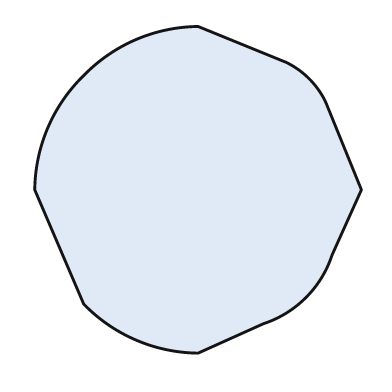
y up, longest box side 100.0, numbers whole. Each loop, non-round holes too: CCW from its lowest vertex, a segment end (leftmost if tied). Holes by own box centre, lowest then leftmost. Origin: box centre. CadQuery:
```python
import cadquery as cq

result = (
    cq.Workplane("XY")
    .moveTo(0.0, -50.0)
    .lineTo(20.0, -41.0)
    .threePointArc((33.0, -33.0), (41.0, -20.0))
    .lineTo(50.0, 0.0)
    .lineTo(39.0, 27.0)
    .threePointArc((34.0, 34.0), (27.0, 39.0))
    .lineTo(0.0, 50.0)
    .threePointArc((-19.0, 46.0), (-35.0, 35.0))
    .threePointArc((-46.0, 19.0), (-50.0, 0.0))
    .lineTo(-35.0, -35.0)
    .threePointArc((-19.0, -46.0), (0.0, -50.0))
    .close()
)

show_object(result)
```